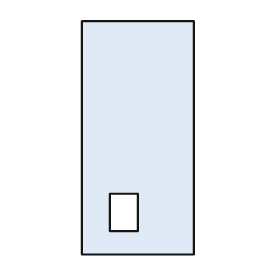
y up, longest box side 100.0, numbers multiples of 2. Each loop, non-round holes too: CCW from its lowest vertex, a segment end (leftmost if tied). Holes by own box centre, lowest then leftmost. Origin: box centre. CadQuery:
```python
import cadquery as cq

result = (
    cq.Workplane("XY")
    .moveTo(-24.0, -50.0)
    .lineTo(24.0, -50.0)
    .lineTo(24.0, 50.0)
    .lineTo(-24.0, 50.0)
    .close()
    .moveTo(-12.0, -40.0)
    .lineTo(0.0, -40.0)
    .lineTo(0.0, -24.0)
    .lineTo(-12.0, -24.0)
    .close()
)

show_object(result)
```